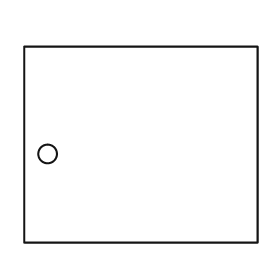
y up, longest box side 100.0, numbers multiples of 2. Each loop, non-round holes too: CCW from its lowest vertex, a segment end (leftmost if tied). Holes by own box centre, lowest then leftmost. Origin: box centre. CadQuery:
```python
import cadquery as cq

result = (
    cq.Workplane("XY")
    .moveTo(-50.0, -42.0)
    .lineTo(50.0, -42.0)
    .lineTo(50.0, 42.0)
    .lineTo(-50.0, 42.0)
    .close()
    .moveTo(-40.0, -4.0)
    .circle(4.0)
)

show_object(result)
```